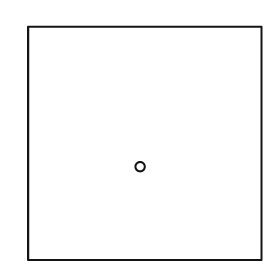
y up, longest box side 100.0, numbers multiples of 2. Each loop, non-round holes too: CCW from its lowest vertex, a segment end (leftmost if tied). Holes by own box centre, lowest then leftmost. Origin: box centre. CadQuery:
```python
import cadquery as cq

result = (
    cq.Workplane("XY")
    .moveTo(-50.0, -50.0)
    .lineTo(50.0, -50.0)
    .lineTo(50.0, 50.0)
    .lineTo(-50.0, 50.0)
    .close()
    .moveTo(-2.0, -10.0)
    .circle(2.0)
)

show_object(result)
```